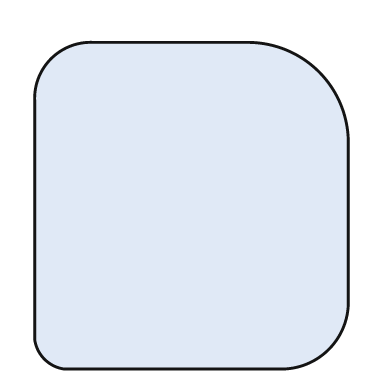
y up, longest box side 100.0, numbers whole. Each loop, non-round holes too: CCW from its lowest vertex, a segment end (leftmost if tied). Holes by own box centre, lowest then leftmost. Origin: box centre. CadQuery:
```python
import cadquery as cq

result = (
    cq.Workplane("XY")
    .moveTo(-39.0, -50.0)
    .lineTo(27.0, -50.0)
    .threePointArc((42.0, -44.0), (48.0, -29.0))
    .lineTo(48.0, 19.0)
    .threePointArc((39.0, 41.0), (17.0, 50.0))
    .lineTo(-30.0, 50.0)
    .threePointArc((-43.0, 45.0), (-48.0, 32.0))
    .lineTo(-48.0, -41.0)
    .threePointArc((-45.0, -47.0), (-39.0, -50.0))
    .close()
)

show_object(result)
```